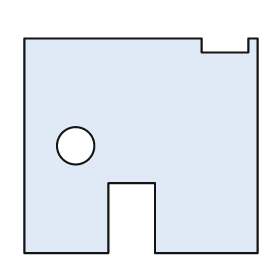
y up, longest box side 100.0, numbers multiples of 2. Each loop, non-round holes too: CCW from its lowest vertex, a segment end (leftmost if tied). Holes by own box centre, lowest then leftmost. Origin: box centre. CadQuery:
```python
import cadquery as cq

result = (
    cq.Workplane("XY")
    .moveTo(-50.0, -46.0)
    .lineTo(-14.0, -46.0)
    .lineTo(-14.0, -16.0)
    .lineTo(6.0, -16.0)
    .lineTo(6.0, -46.0)
    .lineTo(50.0, -46.0)
    .lineTo(50.0, 46.0)
    .lineTo(46.0, 46.0)
    .lineTo(46.0, 40.0)
    .lineTo(26.0, 40.0)
    .lineTo(26.0, 46.0)
    .lineTo(-50.0, 46.0)
    .close()
    .moveTo(-28.0, 0.0)
    .circle(8.0)
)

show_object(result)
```